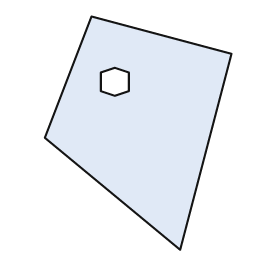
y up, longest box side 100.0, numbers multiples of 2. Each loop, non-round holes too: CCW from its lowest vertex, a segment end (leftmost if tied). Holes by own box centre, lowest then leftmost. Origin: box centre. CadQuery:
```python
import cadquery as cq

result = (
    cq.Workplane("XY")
    .moveTo(18.0, -50.0)
    .lineTo(40.0, 34.0)
    .lineTo(-20.0, 50.0)
    .lineTo(-40.0, -2.0)
    .close()
    .moveTo(-10.0, 16.0)
    .lineTo(-4.0, 18.0)
    .lineTo(-4.0, 26.0)
    .lineTo(-10.0, 28.0)
    .lineTo(-16.0, 26.0)
    .lineTo(-16.0, 18.0)
    .close()
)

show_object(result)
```